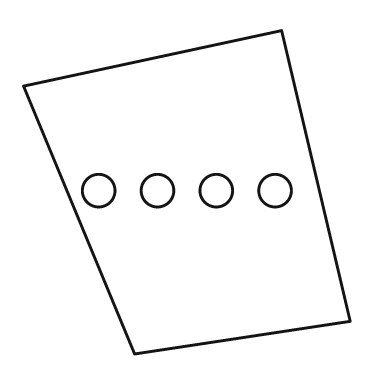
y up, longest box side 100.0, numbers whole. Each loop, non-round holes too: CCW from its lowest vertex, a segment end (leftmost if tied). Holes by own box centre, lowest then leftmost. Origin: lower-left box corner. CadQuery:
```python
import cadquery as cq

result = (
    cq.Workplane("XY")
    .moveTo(34.0, 0.0)
    .lineTo(100.0, 10.0)
    .lineTo(79.0, 99.0)
    .lineTo(0.0, 82.0)
    .close()
    .moveTo(23.0, 50.0)
    .circle(5.0)
    .moveTo(41.0, 50.0)
    .circle(5.0)
    .moveTo(59.0, 50.0)
    .circle(5.0)
    .moveTo(77.0, 50.0)
    .circle(5.0)
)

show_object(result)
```